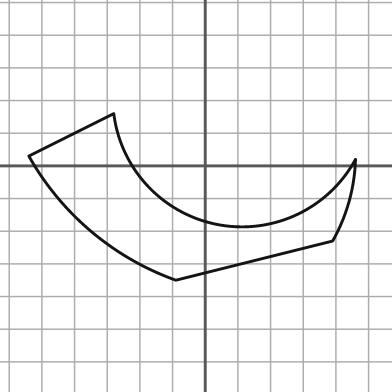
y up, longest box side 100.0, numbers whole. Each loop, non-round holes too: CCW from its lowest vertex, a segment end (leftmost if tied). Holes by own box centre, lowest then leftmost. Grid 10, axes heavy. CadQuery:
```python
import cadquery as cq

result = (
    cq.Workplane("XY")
    .moveTo(-9.0, -35.0)
    .lineTo(39.0, -23.0)
    .threePointArc((44.0, -11.0), (46.0, 2.0))
    .threePointArc((4.0, -18.0), (-28.0, 16.0))
    .lineTo(-54.0, 3.0)
    .threePointArc((-35.0, -20.0), (-9.0, -35.0))
    .close()
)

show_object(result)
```